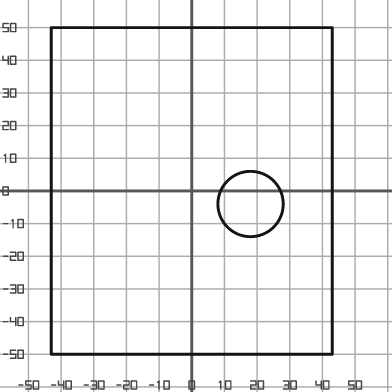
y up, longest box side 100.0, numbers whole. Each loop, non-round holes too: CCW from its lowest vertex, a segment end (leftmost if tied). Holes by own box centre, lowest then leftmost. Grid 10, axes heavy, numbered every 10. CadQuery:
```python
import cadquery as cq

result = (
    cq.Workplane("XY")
    .moveTo(-43.0, -50.0)
    .lineTo(43.0, -50.0)
    .lineTo(43.0, 50.0)
    .lineTo(-43.0, 50.0)
    .close()
    .moveTo(18.0, -4.0)
    .circle(10.0)
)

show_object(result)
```